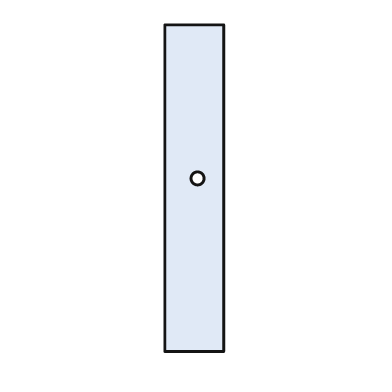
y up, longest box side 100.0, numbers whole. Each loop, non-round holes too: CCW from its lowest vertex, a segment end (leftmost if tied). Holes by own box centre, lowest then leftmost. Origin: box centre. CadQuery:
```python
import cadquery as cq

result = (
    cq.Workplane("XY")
    .moveTo(-9.0, -50.0)
    .lineTo(9.0, -50.0)
    .lineTo(9.0, 50.0)
    .lineTo(-9.0, 50.0)
    .close()
    .moveTo(1.0, 3.0)
    .circle(2.0)
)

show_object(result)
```